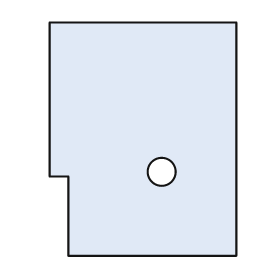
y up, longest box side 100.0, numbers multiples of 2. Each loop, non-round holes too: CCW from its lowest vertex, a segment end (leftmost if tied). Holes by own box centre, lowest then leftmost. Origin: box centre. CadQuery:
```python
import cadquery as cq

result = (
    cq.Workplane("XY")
    .moveTo(-32.0, -50.0)
    .lineTo(40.0, -50.0)
    .lineTo(40.0, 50.0)
    .lineTo(-40.0, 50.0)
    .lineTo(-40.0, -16.0)
    .lineTo(-32.0, -16.0)
    .close()
    .moveTo(8.0, -14.0)
    .circle(6.0)
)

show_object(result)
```